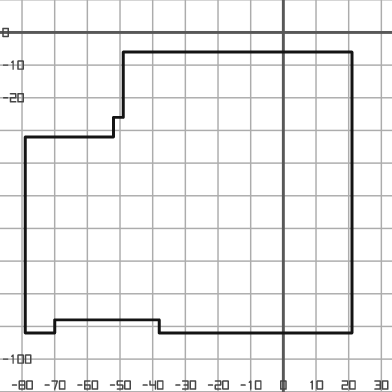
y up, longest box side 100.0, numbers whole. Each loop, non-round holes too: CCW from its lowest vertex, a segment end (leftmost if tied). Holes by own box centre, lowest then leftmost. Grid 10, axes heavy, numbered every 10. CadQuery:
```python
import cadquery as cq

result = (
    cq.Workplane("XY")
    .moveTo(-79.0, -92.0)
    .lineTo(-70.0, -92.0)
    .lineTo(-70.0, -88.0)
    .lineTo(-38.0, -88.0)
    .lineTo(-38.0, -92.0)
    .lineTo(21.0, -92.0)
    .lineTo(21.0, -6.0)
    .lineTo(-49.0, -6.0)
    .lineTo(-49.0, -26.0)
    .lineTo(-52.0, -26.0)
    .lineTo(-52.0, -32.0)
    .lineTo(-79.0, -32.0)
    .close()
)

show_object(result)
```